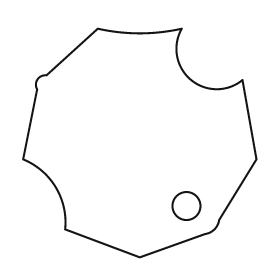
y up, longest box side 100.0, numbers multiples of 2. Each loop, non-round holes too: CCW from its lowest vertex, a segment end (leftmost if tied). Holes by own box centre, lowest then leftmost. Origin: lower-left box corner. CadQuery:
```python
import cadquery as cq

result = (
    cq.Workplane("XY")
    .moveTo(50.0, 0.0)
    .lineTo(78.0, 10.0)
    .threePointArc((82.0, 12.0), (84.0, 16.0))
    .lineTo(100.0, 42.0)
    .lineTo(94.0, 76.0)
    .threePointArc((72.0, 76.0), (68.0, 98.0))
    .threePointArc((50.0, 96.0), (32.0, 98.0))
    .lineTo(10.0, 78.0)
    .threePointArc((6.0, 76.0), (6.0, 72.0))
    .lineTo(0.0, 42.0)
    .threePointArc((14.0, 30.0), (18.0, 12.0))
    .close()
    .moveTo(70.0, 22.0)
    .circle(6.0)
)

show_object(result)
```